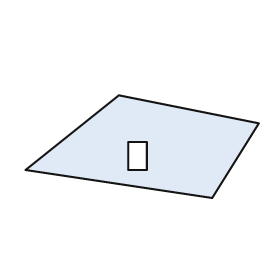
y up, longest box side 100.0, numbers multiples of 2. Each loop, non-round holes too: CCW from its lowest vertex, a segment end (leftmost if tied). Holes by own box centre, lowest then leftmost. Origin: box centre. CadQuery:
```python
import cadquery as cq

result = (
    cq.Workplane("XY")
    .moveTo(30.0, -22.0)
    .lineTo(50.0, 10.0)
    .lineTo(-10.0, 22.0)
    .lineTo(-50.0, -10.0)
    .close()
    .moveTo(-6.0, -10.0)
    .lineTo(2.0, -10.0)
    .lineTo(2.0, 2.0)
    .lineTo(-6.0, 2.0)
    .close()
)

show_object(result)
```